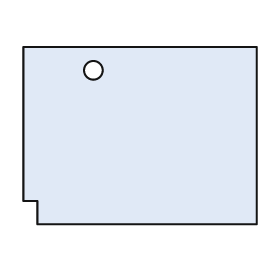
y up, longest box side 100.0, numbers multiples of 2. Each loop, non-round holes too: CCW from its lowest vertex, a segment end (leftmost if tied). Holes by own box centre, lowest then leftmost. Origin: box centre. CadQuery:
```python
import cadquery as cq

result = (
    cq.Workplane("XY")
    .moveTo(-44.0, -38.0)
    .lineTo(50.0, -38.0)
    .lineTo(50.0, 38.0)
    .lineTo(-50.0, 38.0)
    .lineTo(-50.0, -28.0)
    .lineTo(-44.0, -28.0)
    .close()
    .moveTo(-20.0, 28.0)
    .circle(4.0)
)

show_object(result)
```